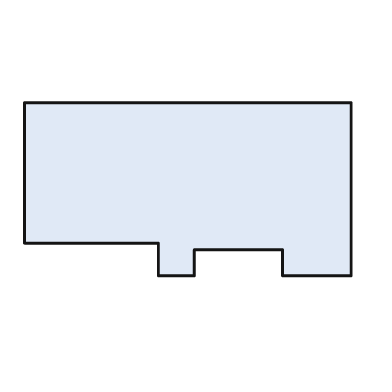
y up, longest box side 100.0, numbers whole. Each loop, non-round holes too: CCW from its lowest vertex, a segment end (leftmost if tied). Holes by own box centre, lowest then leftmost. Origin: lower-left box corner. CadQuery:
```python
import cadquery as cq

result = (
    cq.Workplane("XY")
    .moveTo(41.0, 0.0)
    .lineTo(52.0, 0.0)
    .lineTo(52.0, 8.0)
    .lineTo(79.0, 8.0)
    .lineTo(79.0, 0.0)
    .lineTo(100.0, 0.0)
    .lineTo(100.0, 53.0)
    .lineTo(0.0, 53.0)
    .lineTo(0.0, 10.0)
    .lineTo(41.0, 10.0)
    .close()
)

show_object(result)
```